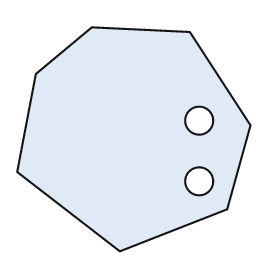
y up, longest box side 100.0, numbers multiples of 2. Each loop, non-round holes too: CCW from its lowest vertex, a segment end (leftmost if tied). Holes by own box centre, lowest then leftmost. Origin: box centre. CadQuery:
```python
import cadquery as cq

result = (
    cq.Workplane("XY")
    .moveTo(-6.0, -48.0)
    .lineTo(40.0, -30.0)
    .lineTo(50.0, 6.0)
    .lineTo(24.0, 46.0)
    .lineTo(-18.0, 48.0)
    .lineTo(-42.0, 28.0)
    .lineTo(-50.0, -14.0)
    .close()
    .moveTo(28.0, -18.0)
    .circle(6.0)
    .moveTo(28.0, 8.0)
    .circle(6.0)
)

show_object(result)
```